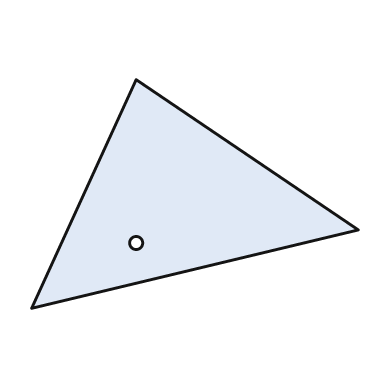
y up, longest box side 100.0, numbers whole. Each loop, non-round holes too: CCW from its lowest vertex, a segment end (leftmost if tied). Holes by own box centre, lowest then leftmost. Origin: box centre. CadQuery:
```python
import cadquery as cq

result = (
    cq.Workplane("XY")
    .moveTo(-50.0, -35.0)
    .lineTo(50.0, -11.0)
    .lineTo(-18.0, 35.0)
    .close()
    .moveTo(-18.0, -15.0)
    .circle(2.0)
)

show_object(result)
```